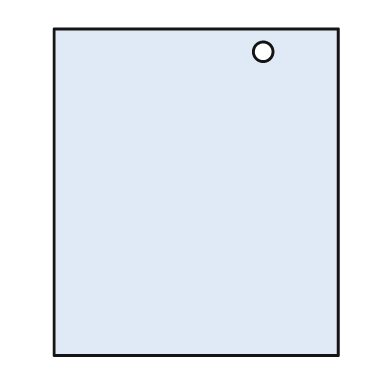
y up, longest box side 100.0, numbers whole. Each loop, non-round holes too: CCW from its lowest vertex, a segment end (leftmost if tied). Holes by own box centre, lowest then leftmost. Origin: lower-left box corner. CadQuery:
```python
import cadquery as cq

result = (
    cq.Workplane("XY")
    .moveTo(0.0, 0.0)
    .lineTo(87.0, 0.0)
    .lineTo(87.0, 100.0)
    .lineTo(0.0, 100.0)
    .close()
    .moveTo(64.0, 93.0)
    .circle(3.0)
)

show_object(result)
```